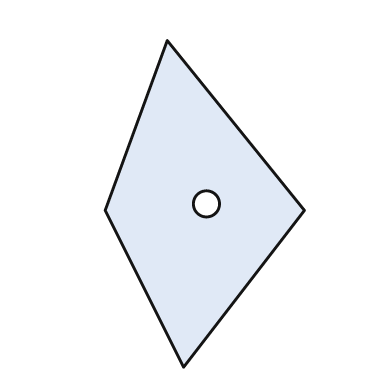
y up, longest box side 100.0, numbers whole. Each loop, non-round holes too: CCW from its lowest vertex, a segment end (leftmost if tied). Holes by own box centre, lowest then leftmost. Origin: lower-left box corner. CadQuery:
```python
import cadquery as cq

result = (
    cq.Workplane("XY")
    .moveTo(24.0, 0.0)
    .lineTo(61.0, 48.0)
    .lineTo(19.0, 100.0)
    .lineTo(0.0, 48.0)
    .close()
    .moveTo(31.0, 50.0)
    .circle(4.0)
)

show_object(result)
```